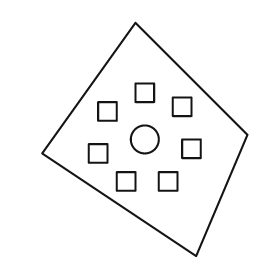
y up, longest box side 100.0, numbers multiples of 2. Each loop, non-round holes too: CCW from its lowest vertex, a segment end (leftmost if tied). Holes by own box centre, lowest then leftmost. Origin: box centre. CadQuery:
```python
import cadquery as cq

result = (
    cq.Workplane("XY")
    .moveTo(22.0, -50.0)
    .lineTo(44.0, 2.0)
    .lineTo(-4.0, 50.0)
    .lineTo(-44.0, -6.0)
    .close()
    .moveTo(-12.0, -22.0)
    .lineTo(-4.0, -22.0)
    .lineTo(-4.0, -14.0)
    .lineTo(-12.0, -14.0)
    .close()
    .moveTo(6.0, -22.0)
    .lineTo(14.0, -22.0)
    .lineTo(14.0, -14.0)
    .lineTo(6.0, -14.0)
    .close()
    .moveTo(-24.0, -10.0)
    .lineTo(-16.0, -10.0)
    .lineTo(-16.0, -2.0)
    .lineTo(-24.0, -2.0)
    .close()
    .moveTo(16.0, -8.0)
    .lineTo(24.0, -8.0)
    .lineTo(24.0, 0.0)
    .lineTo(16.0, 0.0)
    .close()
    .moveTo(0.0, 0.0)
    .circle(6.0)
    .moveTo(-20.0, 8.0)
    .lineTo(-12.0, 8.0)
    .lineTo(-12.0, 16.0)
    .lineTo(-20.0, 16.0)
    .close()
    .moveTo(12.0, 10.0)
    .lineTo(20.0, 10.0)
    .lineTo(20.0, 18.0)
    .lineTo(12.0, 18.0)
    .close()
    .moveTo(-4.0, 16.0)
    .lineTo(4.0, 16.0)
    .lineTo(4.0, 24.0)
    .lineTo(-4.0, 24.0)
    .close()
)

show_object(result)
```